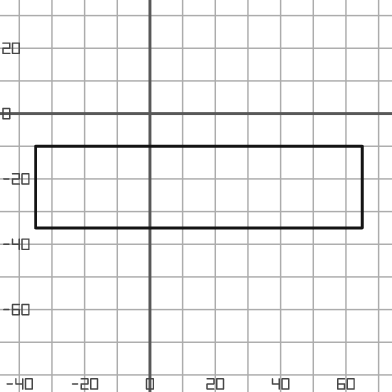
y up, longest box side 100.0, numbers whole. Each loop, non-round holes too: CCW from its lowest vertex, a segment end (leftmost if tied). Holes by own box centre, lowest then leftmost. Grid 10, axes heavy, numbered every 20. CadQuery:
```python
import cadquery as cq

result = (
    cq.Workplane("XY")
    .moveTo(-35.0, -35.0)
    .lineTo(65.0, -35.0)
    .lineTo(65.0, -10.0)
    .lineTo(-35.0, -10.0)
    .close()
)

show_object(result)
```